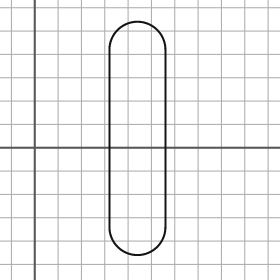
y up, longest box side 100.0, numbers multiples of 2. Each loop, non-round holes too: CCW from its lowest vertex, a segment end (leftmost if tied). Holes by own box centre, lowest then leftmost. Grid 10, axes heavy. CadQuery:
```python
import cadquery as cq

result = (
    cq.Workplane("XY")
    .moveTo(32.0, -34.0)
    .threePointArc((44.0, -46.0), (56.0, -34.0))
    .lineTo(56.0, 42.0)
    .threePointArc((44.0, 54.0), (32.0, 42.0))
    .close()
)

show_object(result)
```